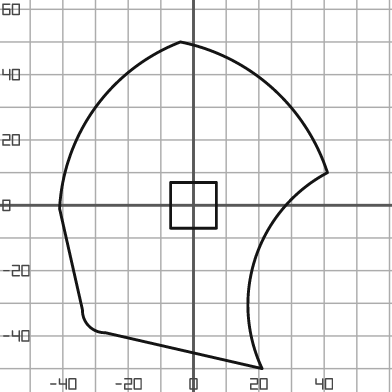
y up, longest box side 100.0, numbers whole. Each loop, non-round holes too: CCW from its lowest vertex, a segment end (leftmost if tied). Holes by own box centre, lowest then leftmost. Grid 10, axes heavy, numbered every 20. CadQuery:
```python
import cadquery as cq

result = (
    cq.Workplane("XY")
    .moveTo(21.0, -50.0)
    .threePointArc((19.0, -16.0), (41.0, 10.0))
    .threePointArc((24.0, 36.0), (-4.0, 50.0))
    .threePointArc((-30.0, 30.0), (-41.0, -1.0))
    .lineTo(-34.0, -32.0)
    .threePointArc((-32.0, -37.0), (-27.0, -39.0))
    .close()
    .moveTo(-7.0, -7.0)
    .lineTo(7.0, -7.0)
    .lineTo(7.0, 7.0)
    .lineTo(-7.0, 7.0)
    .close()
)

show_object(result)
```